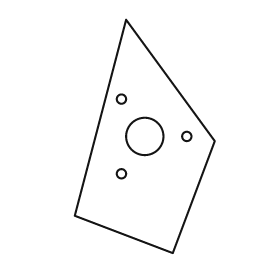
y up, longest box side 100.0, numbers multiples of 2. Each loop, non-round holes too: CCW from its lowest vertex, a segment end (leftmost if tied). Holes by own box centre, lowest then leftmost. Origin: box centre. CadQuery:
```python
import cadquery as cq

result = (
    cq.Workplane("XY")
    .moveTo(12.0, -50.0)
    .lineTo(30.0, -2.0)
    .lineTo(-8.0, 50.0)
    .lineTo(-30.0, -34.0)
    .close()
    .moveTo(-10.0, -16.0)
    .circle(2.0)
    .moveTo(0.0, 0.0)
    .circle(8.0)
    .moveTo(18.0, 0.0)
    .circle(2.0)
    .moveTo(-10.0, 16.0)
    .circle(2.0)
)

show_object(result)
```